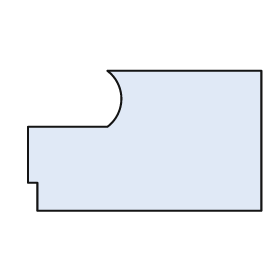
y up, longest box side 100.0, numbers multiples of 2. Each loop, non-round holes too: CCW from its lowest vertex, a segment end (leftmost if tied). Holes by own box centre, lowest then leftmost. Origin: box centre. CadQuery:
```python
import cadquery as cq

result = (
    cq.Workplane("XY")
    .moveTo(-46.0, -30.0)
    .lineTo(50.0, -30.0)
    .lineTo(50.0, 30.0)
    .lineTo(-16.0, 30.0)
    .threePointArc((-10.0, 18.0), (-16.0, 6.0))
    .lineTo(-50.0, 6.0)
    .lineTo(-50.0, -18.0)
    .lineTo(-46.0, -18.0)
    .close()
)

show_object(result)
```